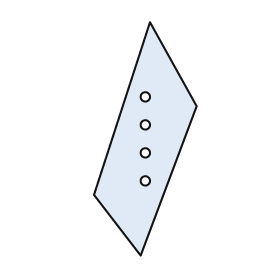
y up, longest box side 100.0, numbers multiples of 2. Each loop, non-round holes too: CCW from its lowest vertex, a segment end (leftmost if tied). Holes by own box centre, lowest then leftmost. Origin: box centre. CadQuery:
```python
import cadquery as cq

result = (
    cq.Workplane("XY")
    .moveTo(-2.0, -50.0)
    .lineTo(22.0, 14.0)
    .lineTo(2.0, 50.0)
    .lineTo(-22.0, -24.0)
    .close()
    .moveTo(0.0, -18.0)
    .circle(2.0)
    .moveTo(0.0, -6.0)
    .circle(2.0)
    .moveTo(0.0, 6.0)
    .circle(2.0)
    .moveTo(0.0, 18.0)
    .circle(2.0)
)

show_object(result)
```